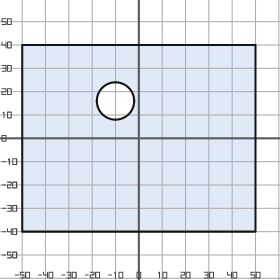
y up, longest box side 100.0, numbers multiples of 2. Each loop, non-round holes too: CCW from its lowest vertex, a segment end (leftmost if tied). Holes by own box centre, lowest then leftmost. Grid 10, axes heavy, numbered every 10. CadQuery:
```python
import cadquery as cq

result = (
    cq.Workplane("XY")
    .moveTo(-50.0, -40.0)
    .lineTo(50.0, -40.0)
    .lineTo(50.0, 40.0)
    .lineTo(-50.0, 40.0)
    .close()
    .moveTo(-10.0, 16.0)
    .circle(8.0)
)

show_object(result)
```